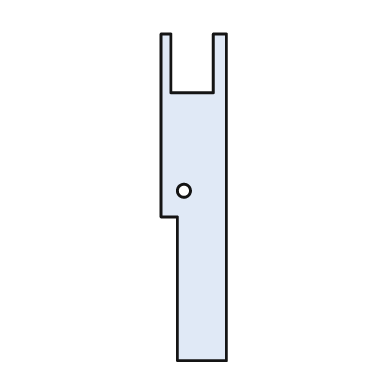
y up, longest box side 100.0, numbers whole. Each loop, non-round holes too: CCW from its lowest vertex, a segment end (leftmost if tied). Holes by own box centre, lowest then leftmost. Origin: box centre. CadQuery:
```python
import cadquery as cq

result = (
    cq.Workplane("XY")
    .moveTo(-5.0, -50.0)
    .lineTo(10.0, -50.0)
    .lineTo(10.0, 50.0)
    .lineTo(6.0, 50.0)
    .lineTo(6.0, 32.0)
    .lineTo(-7.0, 32.0)
    .lineTo(-7.0, 50.0)
    .lineTo(-10.0, 50.0)
    .lineTo(-10.0, -6.0)
    .lineTo(-5.0, -6.0)
    .close()
    .moveTo(-3.0, 2.0)
    .circle(2.0)
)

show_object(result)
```